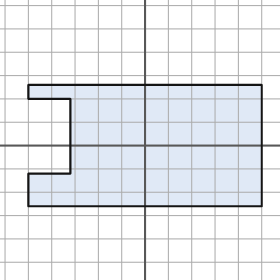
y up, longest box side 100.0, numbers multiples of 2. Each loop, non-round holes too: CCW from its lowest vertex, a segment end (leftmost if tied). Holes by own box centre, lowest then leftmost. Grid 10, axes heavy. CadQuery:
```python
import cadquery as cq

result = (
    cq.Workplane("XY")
    .moveTo(-50.0, -26.0)
    .lineTo(50.0, -26.0)
    .lineTo(50.0, 26.0)
    .lineTo(-50.0, 26.0)
    .lineTo(-50.0, 20.0)
    .lineTo(-32.0, 20.0)
    .lineTo(-32.0, -12.0)
    .lineTo(-50.0, -12.0)
    .close()
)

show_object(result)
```